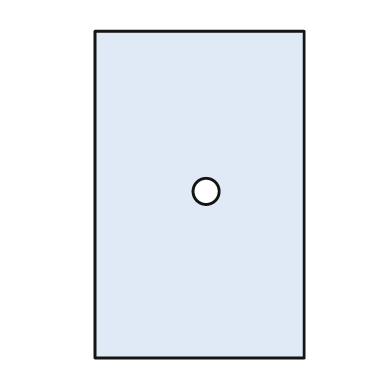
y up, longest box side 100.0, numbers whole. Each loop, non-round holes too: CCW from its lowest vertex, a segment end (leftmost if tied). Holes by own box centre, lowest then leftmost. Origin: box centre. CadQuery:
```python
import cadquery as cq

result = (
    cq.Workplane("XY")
    .moveTo(-32.0, -50.0)
    .lineTo(32.0, -50.0)
    .lineTo(32.0, 50.0)
    .lineTo(-32.0, 50.0)
    .close()
    .moveTo(2.0, 1.0)
    .circle(4.0)
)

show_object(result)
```